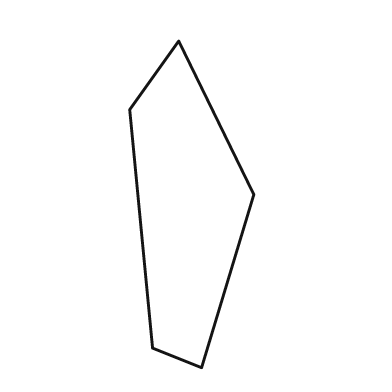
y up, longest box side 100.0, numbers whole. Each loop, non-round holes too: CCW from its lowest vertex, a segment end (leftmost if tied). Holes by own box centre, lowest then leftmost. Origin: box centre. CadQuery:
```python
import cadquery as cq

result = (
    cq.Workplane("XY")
    .moveTo(3.0, -50.0)
    .lineTo(19.0, 3.0)
    .lineTo(-4.0, 50.0)
    .lineTo(-19.0, 29.0)
    .lineTo(-12.0, -44.0)
    .close()
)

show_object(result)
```